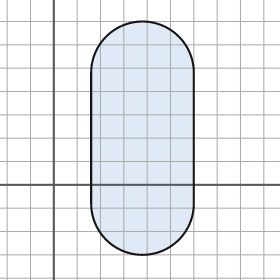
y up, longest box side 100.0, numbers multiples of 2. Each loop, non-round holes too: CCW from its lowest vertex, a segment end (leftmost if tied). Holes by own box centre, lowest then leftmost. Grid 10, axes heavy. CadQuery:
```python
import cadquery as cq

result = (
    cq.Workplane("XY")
    .moveTo(16.0, -8.0)
    .threePointArc((38.0, -30.0), (60.0, -8.0))
    .lineTo(60.0, 48.0)
    .threePointArc((38.0, 70.0), (16.0, 48.0))
    .close()
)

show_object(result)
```